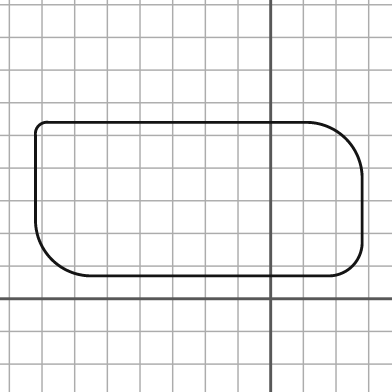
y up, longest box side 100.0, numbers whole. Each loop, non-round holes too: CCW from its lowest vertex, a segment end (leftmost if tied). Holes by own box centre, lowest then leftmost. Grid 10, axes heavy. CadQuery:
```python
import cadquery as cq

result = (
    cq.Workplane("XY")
    .moveTo(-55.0, 7.0)
    .lineTo(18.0, 7.0)
    .threePointArc((25.0, 10.0), (28.0, 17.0))
    .lineTo(28.0, 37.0)
    .threePointArc((23.0, 49.0), (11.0, 54.0))
    .lineTo(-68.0, 54.0)
    .threePointArc((-71.0, 53.0), (-72.0, 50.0))
    .lineTo(-72.0, 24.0)
    .threePointArc((-67.0, 12.0), (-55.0, 7.0))
    .close()
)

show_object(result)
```